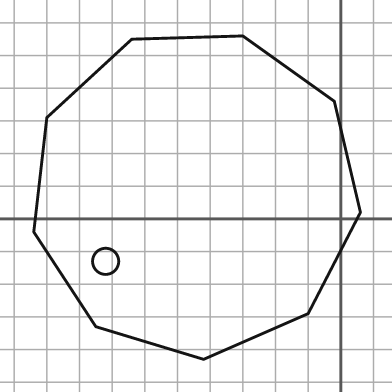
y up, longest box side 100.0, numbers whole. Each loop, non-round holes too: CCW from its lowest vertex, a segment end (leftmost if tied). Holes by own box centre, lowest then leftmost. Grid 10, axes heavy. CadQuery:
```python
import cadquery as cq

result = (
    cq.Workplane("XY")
    .moveTo(-42.0, -43.0)
    .lineTo(-10.0, -29.0)
    .lineTo(6.0, 2.0)
    .lineTo(-2.0, 36.0)
    .lineTo(-30.0, 56.0)
    .lineTo(-64.0, 55.0)
    .lineTo(-90.0, 31.0)
    .lineTo(-94.0, -4.0)
    .lineTo(-75.0, -33.0)
    .close()
    .moveTo(-72.0, -13.0)
    .circle(4.0)
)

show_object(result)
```